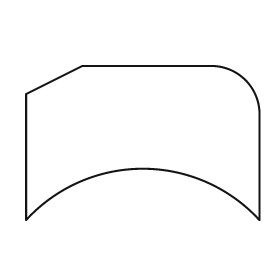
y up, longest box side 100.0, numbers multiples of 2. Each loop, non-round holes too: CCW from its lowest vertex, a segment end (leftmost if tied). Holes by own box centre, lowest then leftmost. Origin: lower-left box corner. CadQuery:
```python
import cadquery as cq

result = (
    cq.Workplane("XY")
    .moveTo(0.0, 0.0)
    .threePointArc((50.0, 22.0), (100.0, 0.0))
    .lineTo(100.0, 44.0)
    .threePointArc((94.0, 60.0), (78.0, 66.0))
    .lineTo(24.0, 66.0)
    .lineTo(0.0, 54.0)
    .close()
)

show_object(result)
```